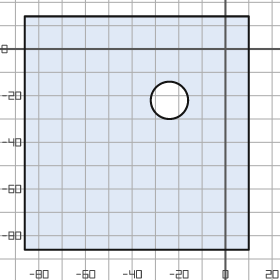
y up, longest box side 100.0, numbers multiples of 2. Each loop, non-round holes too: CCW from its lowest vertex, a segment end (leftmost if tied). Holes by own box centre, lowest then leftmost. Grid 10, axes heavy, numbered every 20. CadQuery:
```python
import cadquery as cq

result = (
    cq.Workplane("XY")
    .moveTo(-86.0, -86.0)
    .lineTo(10.0, -86.0)
    .lineTo(10.0, 14.0)
    .lineTo(-86.0, 14.0)
    .close()
    .moveTo(-24.0, -22.0)
    .circle(8.0)
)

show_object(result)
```